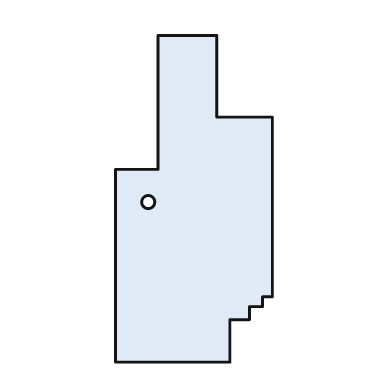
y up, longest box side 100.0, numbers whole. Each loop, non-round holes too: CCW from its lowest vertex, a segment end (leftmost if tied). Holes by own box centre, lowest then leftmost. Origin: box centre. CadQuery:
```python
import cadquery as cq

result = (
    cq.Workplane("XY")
    .moveTo(-24.0, -50.0)
    .lineTo(11.0, -50.0)
    .lineTo(11.0, -37.0)
    .lineTo(17.0, -37.0)
    .lineTo(17.0, -33.0)
    .lineTo(21.0, -33.0)
    .lineTo(21.0, -30.0)
    .lineTo(24.0, -30.0)
    .lineTo(24.0, 25.0)
    .lineTo(7.0, 25.0)
    .lineTo(7.0, 50.0)
    .lineTo(-11.0, 50.0)
    .lineTo(-11.0, 9.0)
    .lineTo(-24.0, 9.0)
    .close()
    .moveTo(-14.0, -1.0)
    .circle(2.0)
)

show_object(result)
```